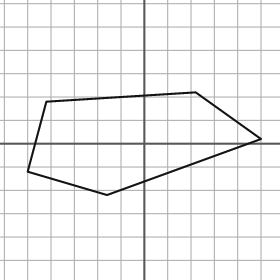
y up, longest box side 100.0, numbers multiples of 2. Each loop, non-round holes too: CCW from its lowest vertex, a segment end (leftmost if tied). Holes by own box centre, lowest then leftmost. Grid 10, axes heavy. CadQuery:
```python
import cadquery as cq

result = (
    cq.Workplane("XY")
    .moveTo(-16.0, -22.0)
    .lineTo(50.0, 2.0)
    .lineTo(22.0, 22.0)
    .lineTo(-42.0, 18.0)
    .lineTo(-50.0, -12.0)
    .close()
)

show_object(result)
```